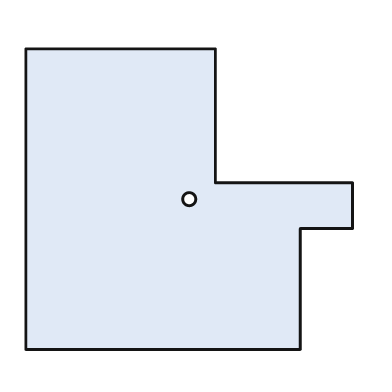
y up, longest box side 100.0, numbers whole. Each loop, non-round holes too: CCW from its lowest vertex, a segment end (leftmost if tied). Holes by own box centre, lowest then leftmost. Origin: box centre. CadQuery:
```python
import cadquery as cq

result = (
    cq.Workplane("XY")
    .moveTo(-50.0, -46.0)
    .lineTo(34.0, -46.0)
    .lineTo(34.0, -9.0)
    .lineTo(50.0, -9.0)
    .lineTo(50.0, 5.0)
    .lineTo(8.0, 5.0)
    .lineTo(8.0, 46.0)
    .lineTo(-50.0, 46.0)
    .close()
    .moveTo(0.0, 0.0)
    .circle(2.0)
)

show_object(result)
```